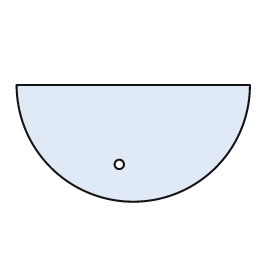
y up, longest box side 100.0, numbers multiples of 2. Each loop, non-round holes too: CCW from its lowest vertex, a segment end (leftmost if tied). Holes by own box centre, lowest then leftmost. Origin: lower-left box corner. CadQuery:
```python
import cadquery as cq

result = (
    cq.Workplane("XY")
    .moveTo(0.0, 50.0)
    .threePointArc((50.0, 0.0), (100.0, 50.0))
    .close()
    .moveTo(44.0, 16.0)
    .circle(2.0)
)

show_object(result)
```